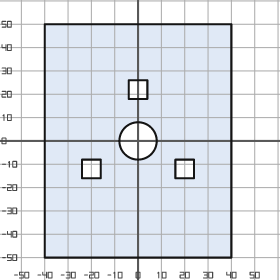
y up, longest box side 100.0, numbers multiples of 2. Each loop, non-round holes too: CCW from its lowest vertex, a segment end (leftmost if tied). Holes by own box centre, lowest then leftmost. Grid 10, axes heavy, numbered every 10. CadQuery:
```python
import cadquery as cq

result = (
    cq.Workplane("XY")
    .moveTo(-40.0, -50.0)
    .lineTo(40.0, -50.0)
    .lineTo(40.0, 50.0)
    .lineTo(-40.0, 50.0)
    .close()
    .moveTo(-24.0, -16.0)
    .lineTo(-16.0, -16.0)
    .lineTo(-16.0, -8.0)
    .lineTo(-24.0, -8.0)
    .close()
    .moveTo(16.0, -16.0)
    .lineTo(24.0, -16.0)
    .lineTo(24.0, -8.0)
    .lineTo(16.0, -8.0)
    .close()
    .moveTo(0.0, 0.0)
    .circle(8.0)
    .moveTo(-4.0, 18.0)
    .lineTo(4.0, 18.0)
    .lineTo(4.0, 26.0)
    .lineTo(-4.0, 26.0)
    .close()
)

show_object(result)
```